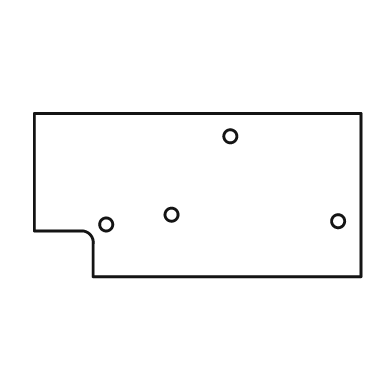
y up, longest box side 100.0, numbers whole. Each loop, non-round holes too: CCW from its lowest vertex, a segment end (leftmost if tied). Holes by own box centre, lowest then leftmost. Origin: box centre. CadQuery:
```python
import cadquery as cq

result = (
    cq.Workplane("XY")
    .moveTo(-32.0, -25.0)
    .lineTo(50.0, -25.0)
    .lineTo(50.0, 25.0)
    .lineTo(-50.0, 25.0)
    .lineTo(-50.0, -11.0)
    .lineTo(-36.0, -11.0)
    .threePointArc((-33.0, -12.0), (-32.0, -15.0))
    .close()
    .moveTo(-28.0, -9.0)
    .circle(2.0)
    .moveTo(43.0, -8.0)
    .circle(2.0)
    .moveTo(-8.0, -6.0)
    .circle(2.0)
    .moveTo(10.0, 18.0)
    .circle(2.0)
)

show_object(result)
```